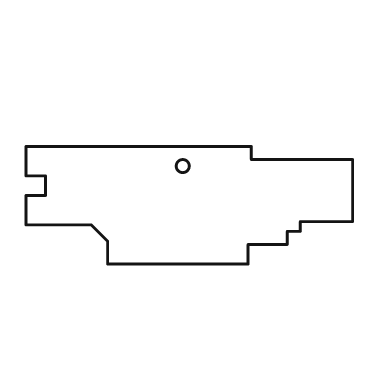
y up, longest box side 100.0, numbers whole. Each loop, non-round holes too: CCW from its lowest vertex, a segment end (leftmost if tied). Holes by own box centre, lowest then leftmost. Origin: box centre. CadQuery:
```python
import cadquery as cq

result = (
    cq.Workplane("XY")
    .moveTo(-25.0, -18.0)
    .lineTo(18.0, -18.0)
    .lineTo(18.0, -12.0)
    .lineTo(30.0, -12.0)
    .lineTo(30.0, -8.0)
    .lineTo(34.0, -8.0)
    .lineTo(34.0, -5.0)
    .lineTo(50.0, -5.0)
    .lineTo(50.0, 14.0)
    .lineTo(19.0, 14.0)
    .lineTo(19.0, 18.0)
    .lineTo(-50.0, 18.0)
    .lineTo(-50.0, 9.0)
    .lineTo(-44.0, 9.0)
    .lineTo(-44.0, 3.0)
    .lineTo(-50.0, 3.0)
    .lineTo(-50.0, -6.0)
    .lineTo(-30.0, -6.0)
    .lineTo(-25.0, -11.0)
    .close()
    .moveTo(-2.0, 12.0)
    .circle(2.0)
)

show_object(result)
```